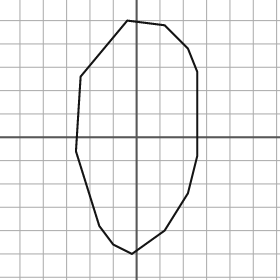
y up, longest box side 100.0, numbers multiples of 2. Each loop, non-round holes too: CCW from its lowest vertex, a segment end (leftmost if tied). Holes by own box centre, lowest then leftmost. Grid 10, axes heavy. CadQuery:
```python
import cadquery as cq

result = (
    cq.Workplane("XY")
    .moveTo(-2.0, -50.0)
    .lineTo(12.0, -40.0)
    .lineTo(22.0, -24.0)
    .lineTo(26.0, -8.0)
    .lineTo(26.0, 28.0)
    .lineTo(22.0, 38.0)
    .lineTo(12.0, 48.0)
    .lineTo(-4.0, 50.0)
    .lineTo(-24.0, 26.0)
    .lineTo(-26.0, -6.0)
    .lineTo(-16.0, -38.0)
    .lineTo(-10.0, -46.0)
    .close()
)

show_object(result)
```